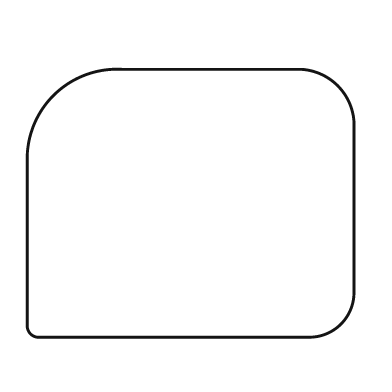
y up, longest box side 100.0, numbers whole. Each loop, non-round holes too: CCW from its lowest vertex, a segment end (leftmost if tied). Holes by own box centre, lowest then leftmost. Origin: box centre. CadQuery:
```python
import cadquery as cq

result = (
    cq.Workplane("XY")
    .moveTo(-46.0, -41.0)
    .lineTo(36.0, -41.0)
    .threePointArc((46.0, -37.0), (50.0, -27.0))
    .lineTo(50.0, 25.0)
    .threePointArc((45.0, 36.0), (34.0, 41.0))
    .lineTo(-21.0, 41.0)
    .threePointArc((-42.0, 33.0), (-50.0, 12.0))
    .lineTo(-50.0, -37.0)
    .threePointArc((-49.0, -40.0), (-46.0, -41.0))
    .close()
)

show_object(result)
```